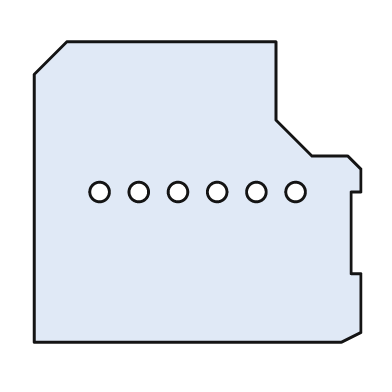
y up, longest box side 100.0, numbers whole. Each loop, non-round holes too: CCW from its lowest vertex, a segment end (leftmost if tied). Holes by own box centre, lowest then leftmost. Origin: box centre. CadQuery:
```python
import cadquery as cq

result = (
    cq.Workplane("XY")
    .moveTo(-50.0, -46.0)
    .lineTo(44.0, -46.0)
    .lineTo(50.0, -43.0)
    .lineTo(50.0, -25.0)
    .lineTo(47.0, -25.0)
    .lineTo(47.0, 0.0)
    .lineTo(50.0, 0.0)
    .lineTo(50.0, 7.0)
    .lineTo(46.0, 11.0)
    .lineTo(35.0, 11.0)
    .lineTo(24.0, 22.0)
    .lineTo(24.0, 46.0)
    .lineTo(-40.0, 46.0)
    .lineTo(-50.0, 36.0)
    .close()
    .moveTo(-30.0, 0.0)
    .circle(3.0)
    .moveTo(-18.0, 0.0)
    .circle(3.0)
    .moveTo(-6.0, 0.0)
    .circle(3.0)
    .moveTo(6.0, 0.0)
    .circle(3.0)
    .moveTo(18.0, 0.0)
    .circle(3.0)
    .moveTo(30.0, 0.0)
    .circle(3.0)
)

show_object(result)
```